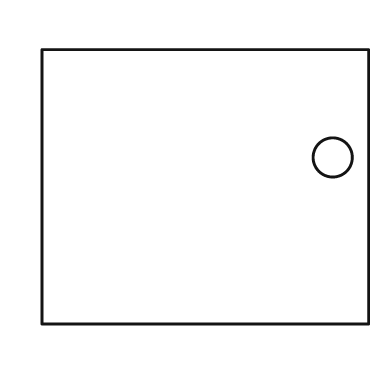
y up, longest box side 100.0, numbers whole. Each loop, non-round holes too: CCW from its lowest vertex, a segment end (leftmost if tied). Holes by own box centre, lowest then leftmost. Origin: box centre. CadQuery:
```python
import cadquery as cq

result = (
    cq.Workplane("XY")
    .moveTo(-50.0, -42.0)
    .lineTo(50.0, -42.0)
    .lineTo(50.0, 42.0)
    .lineTo(-50.0, 42.0)
    .close()
    .moveTo(39.0, 9.0)
    .circle(6.0)
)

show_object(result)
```